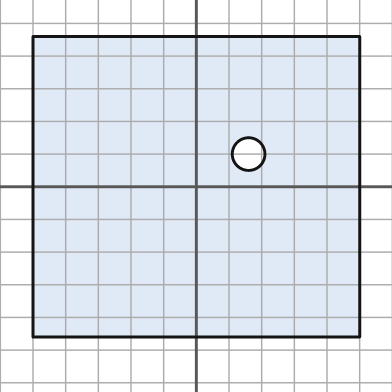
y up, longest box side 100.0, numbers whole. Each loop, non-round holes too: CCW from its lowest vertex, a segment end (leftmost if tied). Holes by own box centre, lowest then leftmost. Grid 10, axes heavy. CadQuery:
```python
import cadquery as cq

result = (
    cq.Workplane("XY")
    .moveTo(-50.0, -46.0)
    .lineTo(50.0, -46.0)
    .lineTo(50.0, 46.0)
    .lineTo(-50.0, 46.0)
    .close()
    .moveTo(16.0, 10.0)
    .circle(5.0)
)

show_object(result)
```